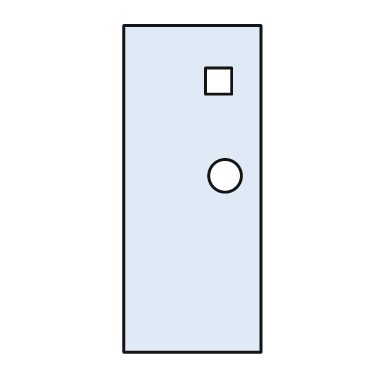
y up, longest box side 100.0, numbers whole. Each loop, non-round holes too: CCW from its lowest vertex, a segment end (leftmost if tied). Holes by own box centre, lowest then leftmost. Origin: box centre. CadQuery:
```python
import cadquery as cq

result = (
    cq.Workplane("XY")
    .moveTo(-21.0, -50.0)
    .lineTo(21.0, -50.0)
    .lineTo(21.0, 50.0)
    .lineTo(-21.0, 50.0)
    .close()
    .moveTo(10.0, 4.0)
    .circle(5.0)
    .moveTo(4.0, 29.0)
    .lineTo(12.0, 29.0)
    .lineTo(12.0, 37.0)
    .lineTo(4.0, 37.0)
    .close()
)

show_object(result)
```